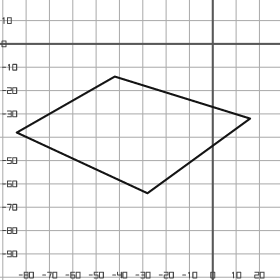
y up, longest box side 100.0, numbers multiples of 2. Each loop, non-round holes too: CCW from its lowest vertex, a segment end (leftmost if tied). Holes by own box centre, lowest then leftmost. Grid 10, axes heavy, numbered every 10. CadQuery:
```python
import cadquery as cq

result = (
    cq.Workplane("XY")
    .moveTo(-28.0, -64.0)
    .lineTo(16.0, -32.0)
    .lineTo(-42.0, -14.0)
    .lineTo(-84.0, -38.0)
    .close()
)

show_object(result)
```